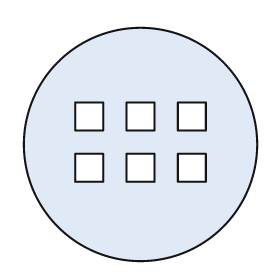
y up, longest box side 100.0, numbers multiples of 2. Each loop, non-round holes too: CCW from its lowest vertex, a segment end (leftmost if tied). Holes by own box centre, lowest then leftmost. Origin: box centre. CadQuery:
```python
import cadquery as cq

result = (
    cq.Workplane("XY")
    .moveTo(0.0, 0.0)
    .circle(50.0)
    .moveTo(-28.0, -16.0)
    .lineTo(-16.0, -16.0)
    .lineTo(-16.0, -4.0)
    .lineTo(-28.0, -4.0)
    .close()
    .moveTo(-6.0, -16.0)
    .lineTo(6.0, -16.0)
    .lineTo(6.0, -4.0)
    .lineTo(-6.0, -4.0)
    .close()
    .moveTo(16.0, -16.0)
    .lineTo(28.0, -16.0)
    .lineTo(28.0, -4.0)
    .lineTo(16.0, -4.0)
    .close()
    .moveTo(-28.0, 6.0)
    .lineTo(-16.0, 6.0)
    .lineTo(-16.0, 18.0)
    .lineTo(-28.0, 18.0)
    .close()
    .moveTo(-6.0, 6.0)
    .lineTo(6.0, 6.0)
    .lineTo(6.0, 18.0)
    .lineTo(-6.0, 18.0)
    .close()
    .moveTo(16.0, 6.0)
    .lineTo(28.0, 6.0)
    .lineTo(28.0, 18.0)
    .lineTo(16.0, 18.0)
    .close()
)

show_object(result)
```